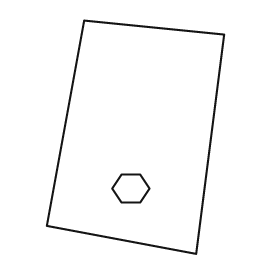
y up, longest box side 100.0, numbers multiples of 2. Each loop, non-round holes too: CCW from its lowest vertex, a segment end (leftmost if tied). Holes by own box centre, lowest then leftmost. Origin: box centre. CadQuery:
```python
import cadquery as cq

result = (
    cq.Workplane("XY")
    .moveTo(26.0, -50.0)
    .lineTo(38.0, 44.0)
    .lineTo(-22.0, 50.0)
    .lineTo(-38.0, -38.0)
    .close()
    .moveTo(-6.0, -28.0)
    .lineTo(2.0, -28.0)
    .lineTo(6.0, -22.0)
    .lineTo(2.0, -16.0)
    .lineTo(-6.0, -16.0)
    .lineTo(-10.0, -22.0)
    .close()
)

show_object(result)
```